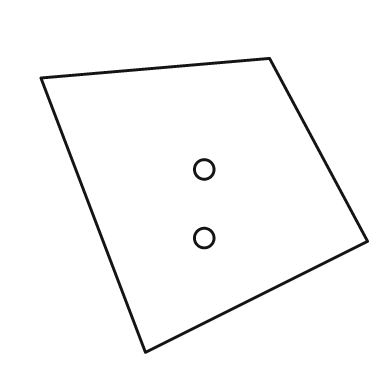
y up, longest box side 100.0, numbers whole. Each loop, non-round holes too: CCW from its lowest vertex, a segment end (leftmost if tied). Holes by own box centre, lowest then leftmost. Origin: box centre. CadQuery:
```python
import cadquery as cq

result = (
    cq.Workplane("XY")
    .moveTo(-18.0, -45.0)
    .lineTo(50.0, -11.0)
    .lineTo(20.0, 45.0)
    .lineTo(-50.0, 39.0)
    .close()
    .moveTo(0.0, -10.0)
    .circle(3.0)
    .moveTo(0.0, 11.0)
    .circle(3.0)
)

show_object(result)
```